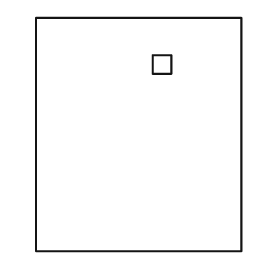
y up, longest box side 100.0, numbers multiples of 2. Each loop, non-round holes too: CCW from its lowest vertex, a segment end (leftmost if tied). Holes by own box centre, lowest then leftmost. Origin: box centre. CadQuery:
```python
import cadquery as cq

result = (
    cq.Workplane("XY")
    .moveTo(-44.0, -50.0)
    .lineTo(44.0, -50.0)
    .lineTo(44.0, 50.0)
    .lineTo(-44.0, 50.0)
    .close()
    .moveTo(6.0, 26.0)
    .lineTo(14.0, 26.0)
    .lineTo(14.0, 34.0)
    .lineTo(6.0, 34.0)
    .close()
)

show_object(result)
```